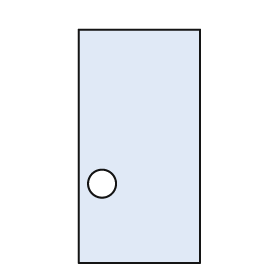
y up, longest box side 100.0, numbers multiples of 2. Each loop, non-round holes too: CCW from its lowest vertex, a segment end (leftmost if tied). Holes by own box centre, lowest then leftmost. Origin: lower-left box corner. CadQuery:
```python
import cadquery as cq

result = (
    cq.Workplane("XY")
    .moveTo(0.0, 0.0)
    .lineTo(52.0, 0.0)
    .lineTo(52.0, 100.0)
    .lineTo(0.0, 100.0)
    .close()
    .moveTo(10.0, 34.0)
    .circle(6.0)
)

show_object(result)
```